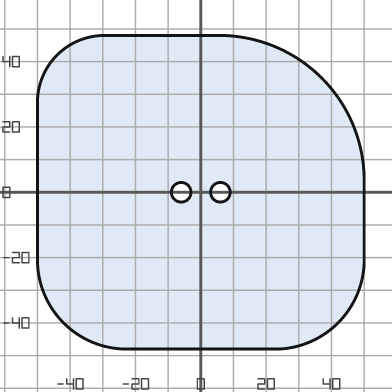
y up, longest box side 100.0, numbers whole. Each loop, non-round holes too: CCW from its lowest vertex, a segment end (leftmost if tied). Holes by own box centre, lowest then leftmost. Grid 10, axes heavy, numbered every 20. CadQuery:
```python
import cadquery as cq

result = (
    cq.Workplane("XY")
    .moveTo(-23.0, -48.0)
    .lineTo(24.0, -48.0)
    .threePointArc((42.0, -40.0), (50.0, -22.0))
    .lineTo(50.0, 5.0)
    .threePointArc((37.0, 35.0), (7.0, 48.0))
    .lineTo(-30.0, 48.0)
    .threePointArc((-44.0, 42.0), (-50.0, 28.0))
    .lineTo(-50.0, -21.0)
    .threePointArc((-42.0, -40.0), (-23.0, -48.0))
    .close()
    .moveTo(-6.0, 0.0)
    .circle(3.0)
    .moveTo(6.0, 0.0)
    .circle(3.0)
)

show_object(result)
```